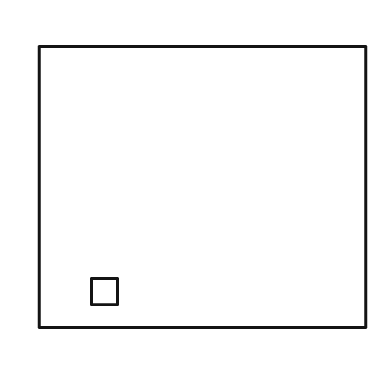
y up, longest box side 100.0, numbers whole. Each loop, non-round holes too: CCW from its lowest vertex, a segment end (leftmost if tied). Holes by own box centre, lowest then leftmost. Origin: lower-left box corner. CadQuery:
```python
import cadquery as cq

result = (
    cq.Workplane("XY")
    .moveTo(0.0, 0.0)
    .lineTo(100.0, 0.0)
    .lineTo(100.0, 86.0)
    .lineTo(0.0, 86.0)
    .close()
    .moveTo(16.0, 7.0)
    .lineTo(24.0, 7.0)
    .lineTo(24.0, 15.0)
    .lineTo(16.0, 15.0)
    .close()
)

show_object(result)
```